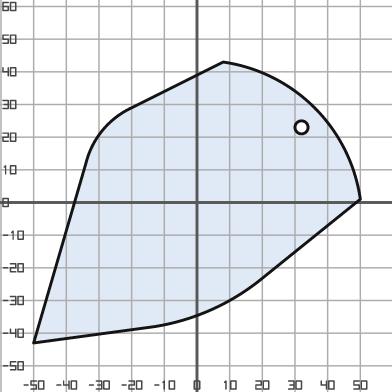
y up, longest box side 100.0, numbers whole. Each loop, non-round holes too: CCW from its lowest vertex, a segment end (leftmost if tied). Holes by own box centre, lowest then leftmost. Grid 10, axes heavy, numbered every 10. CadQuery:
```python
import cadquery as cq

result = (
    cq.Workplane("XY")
    .moveTo(-50.0, -43.0)
    .lineTo(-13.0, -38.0)
    .threePointArc((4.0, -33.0), (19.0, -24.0))
    .lineTo(50.0, 1.0)
    .threePointArc((36.0, 29.0), (8.0, 43.0))
    .lineTo(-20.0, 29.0)
    .threePointArc((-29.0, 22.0), (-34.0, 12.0))
    .close()
    .moveTo(32.0, 23.0)
    .circle(2.0)
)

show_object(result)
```